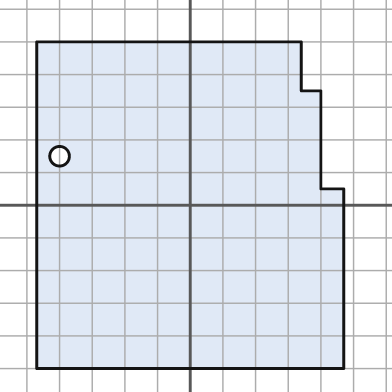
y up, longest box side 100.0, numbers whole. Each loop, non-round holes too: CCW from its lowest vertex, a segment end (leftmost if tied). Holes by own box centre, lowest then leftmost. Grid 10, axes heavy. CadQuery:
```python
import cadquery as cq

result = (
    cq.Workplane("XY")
    .moveTo(-47.0, -50.0)
    .lineTo(47.0, -50.0)
    .lineTo(47.0, 5.0)
    .lineTo(40.0, 5.0)
    .lineTo(40.0, 35.0)
    .lineTo(34.0, 35.0)
    .lineTo(34.0, 50.0)
    .lineTo(-47.0, 50.0)
    .close()
    .moveTo(-40.0, 15.0)
    .circle(3.0)
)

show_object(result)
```